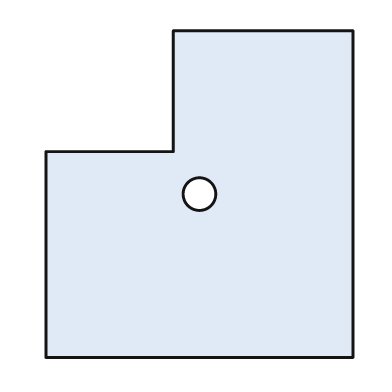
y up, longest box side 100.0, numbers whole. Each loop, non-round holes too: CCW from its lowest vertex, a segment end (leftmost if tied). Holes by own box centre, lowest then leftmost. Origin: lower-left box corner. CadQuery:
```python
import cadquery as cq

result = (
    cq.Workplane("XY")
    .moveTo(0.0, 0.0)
    .lineTo(94.0, 0.0)
    .lineTo(94.0, 100.0)
    .lineTo(39.0, 100.0)
    .lineTo(39.0, 63.0)
    .lineTo(0.0, 63.0)
    .close()
    .moveTo(47.0, 50.0)
    .circle(5.0)
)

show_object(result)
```